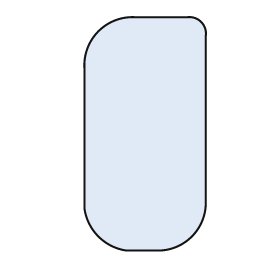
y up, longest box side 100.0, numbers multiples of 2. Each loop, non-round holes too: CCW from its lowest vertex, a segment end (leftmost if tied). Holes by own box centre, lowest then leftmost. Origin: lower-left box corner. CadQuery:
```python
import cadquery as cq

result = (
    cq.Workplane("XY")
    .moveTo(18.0, 0.0)
    .lineTo(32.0, 0.0)
    .threePointArc((46.0, 6.0), (52.0, 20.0))
    .lineTo(52.0, 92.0)
    .threePointArc((50.0, 98.0), (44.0, 100.0))
    .lineTo(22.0, 100.0)
    .threePointArc((6.0, 94.0), (0.0, 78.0))
    .lineTo(0.0, 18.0)
    .threePointArc((6.0, 6.0), (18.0, 0.0))
    .close()
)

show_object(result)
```